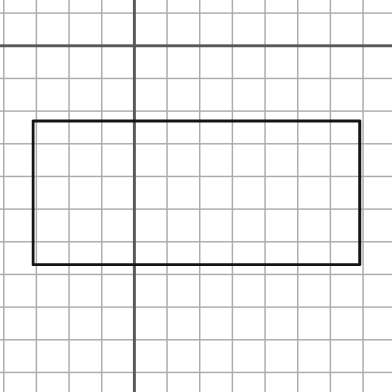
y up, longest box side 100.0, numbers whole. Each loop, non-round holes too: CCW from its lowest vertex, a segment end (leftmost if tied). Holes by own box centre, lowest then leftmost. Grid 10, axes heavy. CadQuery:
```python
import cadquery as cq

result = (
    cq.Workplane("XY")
    .moveTo(-31.0, -67.0)
    .lineTo(69.0, -67.0)
    .lineTo(69.0, -23.0)
    .lineTo(-31.0, -23.0)
    .close()
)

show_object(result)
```